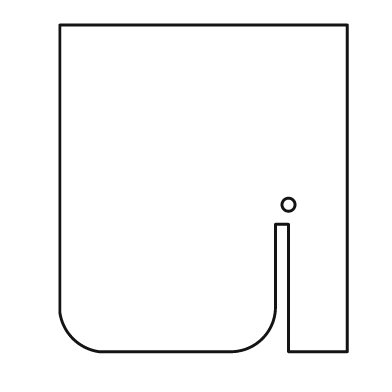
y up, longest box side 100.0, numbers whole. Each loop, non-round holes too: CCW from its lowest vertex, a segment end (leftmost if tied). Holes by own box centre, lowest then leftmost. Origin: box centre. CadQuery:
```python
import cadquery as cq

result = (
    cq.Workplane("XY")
    .moveTo(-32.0, -50.0)
    .lineTo(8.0, -50.0)
    .threePointArc((18.0, -46.0), (22.0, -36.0))
    .lineTo(22.0, -11.0)
    .lineTo(26.0, -11.0)
    .lineTo(26.0, -50.0)
    .lineTo(44.0, -50.0)
    .lineTo(44.0, 50.0)
    .lineTo(-44.0, 50.0)
    .lineTo(-44.0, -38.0)
    .threePointArc((-40.0, -46.0), (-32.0, -50.0))
    .close()
    .moveTo(26.0, -5.0)
    .circle(2.0)
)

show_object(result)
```